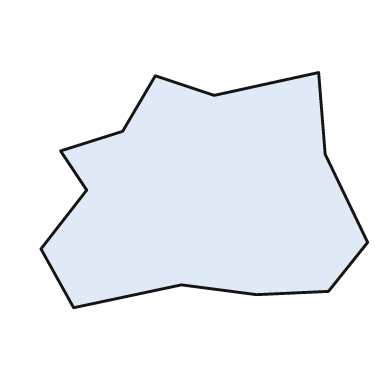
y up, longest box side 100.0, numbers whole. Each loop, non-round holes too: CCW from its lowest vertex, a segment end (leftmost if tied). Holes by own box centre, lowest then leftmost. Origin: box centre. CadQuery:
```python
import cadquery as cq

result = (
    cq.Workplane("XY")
    .moveTo(-40.0, -36.0)
    .lineTo(-7.0, -29.0)
    .lineTo(16.0, -32.0)
    .lineTo(38.0, -31.0)
    .lineTo(50.0, -16.0)
    .lineTo(37.0, 11.0)
    .lineTo(35.0, 36.0)
    .lineTo(3.0, 29.0)
    .lineTo(-15.0, 35.0)
    .lineTo(-25.0, 18.0)
    .lineTo(-44.0, 12.0)
    .lineTo(-36.0, 0.0)
    .lineTo(-50.0, -18.0)
    .close()
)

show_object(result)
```